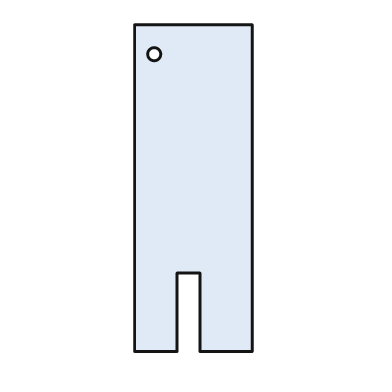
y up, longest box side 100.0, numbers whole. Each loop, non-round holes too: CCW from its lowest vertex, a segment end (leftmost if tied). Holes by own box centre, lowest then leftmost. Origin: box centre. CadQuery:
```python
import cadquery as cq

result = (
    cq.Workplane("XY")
    .moveTo(-18.0, -50.0)
    .lineTo(-5.0, -50.0)
    .lineTo(-5.0, -26.0)
    .lineTo(2.0, -26.0)
    .lineTo(2.0, -50.0)
    .lineTo(18.0, -50.0)
    .lineTo(18.0, 50.0)
    .lineTo(-18.0, 50.0)
    .close()
    .moveTo(-12.0, 41.0)
    .circle(2.0)
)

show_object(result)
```